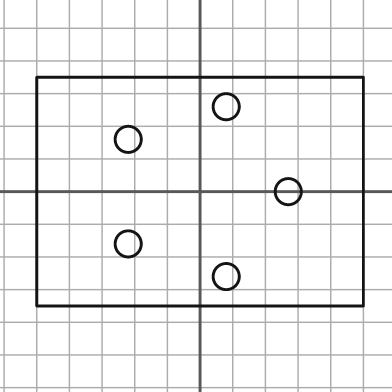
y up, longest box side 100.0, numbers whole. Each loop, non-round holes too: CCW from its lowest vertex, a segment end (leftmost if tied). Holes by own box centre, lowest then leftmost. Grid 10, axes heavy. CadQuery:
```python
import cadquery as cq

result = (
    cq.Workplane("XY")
    .moveTo(-50.0, -35.0)
    .lineTo(50.0, -35.0)
    .lineTo(50.0, 35.0)
    .lineTo(-50.0, 35.0)
    .close()
    .moveTo(8.0, -26.0)
    .circle(4.0)
    .moveTo(-22.0, -16.0)
    .circle(4.0)
    .moveTo(27.0, 0.0)
    .circle(4.0)
    .moveTo(-22.0, 16.0)
    .circle(4.0)
    .moveTo(8.0, 26.0)
    .circle(4.0)
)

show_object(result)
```